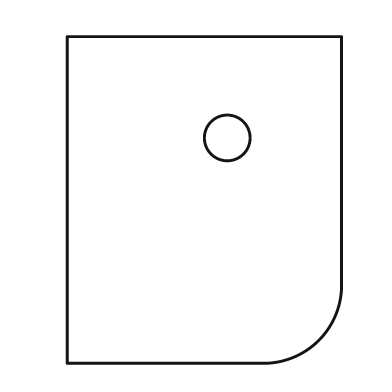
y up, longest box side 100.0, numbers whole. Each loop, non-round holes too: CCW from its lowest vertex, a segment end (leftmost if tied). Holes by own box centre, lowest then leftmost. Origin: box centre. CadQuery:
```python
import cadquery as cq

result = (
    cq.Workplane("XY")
    .moveTo(-42.0, -50.0)
    .lineTo(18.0, -50.0)
    .threePointArc((35.0, -43.0), (42.0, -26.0))
    .lineTo(42.0, 50.0)
    .lineTo(-42.0, 50.0)
    .close()
    .moveTo(7.0, 19.0)
    .circle(7.0)
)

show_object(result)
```